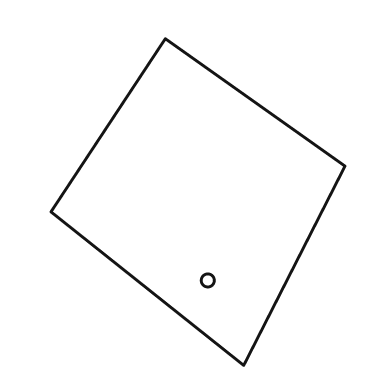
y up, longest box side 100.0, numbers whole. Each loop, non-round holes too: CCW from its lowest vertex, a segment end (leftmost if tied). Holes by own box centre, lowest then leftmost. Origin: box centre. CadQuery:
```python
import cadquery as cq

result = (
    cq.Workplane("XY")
    .moveTo(14.0, -50.0)
    .lineTo(45.0, 11.0)
    .lineTo(-10.0, 50.0)
    .lineTo(-45.0, -3.0)
    .close()
    .moveTo(3.0, -24.0)
    .circle(2.0)
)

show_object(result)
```